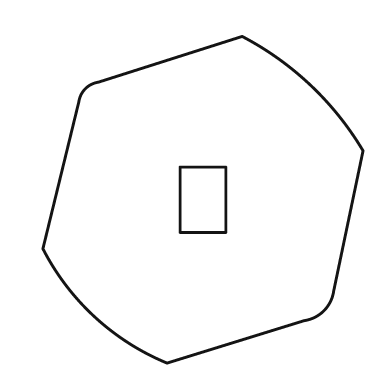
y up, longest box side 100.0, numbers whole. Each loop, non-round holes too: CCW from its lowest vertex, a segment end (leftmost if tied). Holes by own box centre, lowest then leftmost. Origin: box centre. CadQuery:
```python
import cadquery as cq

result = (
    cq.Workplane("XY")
    .moveTo(-11.0, -50.0)
    .lineTo(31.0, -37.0)
    .threePointArc((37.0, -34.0), (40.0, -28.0))
    .lineTo(49.0, 15.0)
    .threePointArc((33.0, 35.0), (12.0, 50.0))
    .lineTo(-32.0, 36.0)
    .threePointArc((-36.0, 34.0), (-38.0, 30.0))
    .lineTo(-49.0, -15.0)
    .threePointArc((-33.0, -36.0), (-11.0, -50.0))
    .close()
    .moveTo(-7.0, -10.0)
    .lineTo(7.0, -10.0)
    .lineTo(7.0, 10.0)
    .lineTo(-7.0, 10.0)
    .close()
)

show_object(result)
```